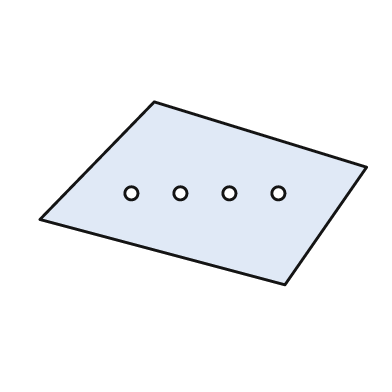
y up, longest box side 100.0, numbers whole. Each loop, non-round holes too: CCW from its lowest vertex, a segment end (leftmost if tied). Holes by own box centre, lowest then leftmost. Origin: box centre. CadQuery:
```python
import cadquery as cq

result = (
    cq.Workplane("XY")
    .moveTo(25.0, -28.0)
    .lineTo(50.0, 8.0)
    .lineTo(-15.0, 28.0)
    .lineTo(-50.0, -8.0)
    .close()
    .moveTo(-22.0, 0.0)
    .circle(2.0)
    .moveTo(-7.0, 0.0)
    .circle(2.0)
    .moveTo(8.0, 0.0)
    .circle(2.0)
    .moveTo(23.0, 0.0)
    .circle(2.0)
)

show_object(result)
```